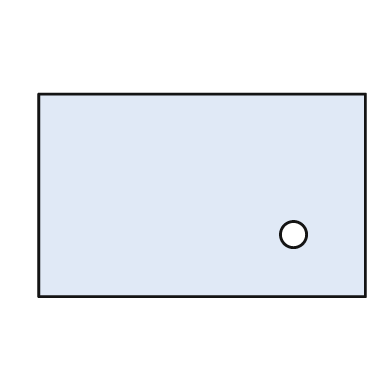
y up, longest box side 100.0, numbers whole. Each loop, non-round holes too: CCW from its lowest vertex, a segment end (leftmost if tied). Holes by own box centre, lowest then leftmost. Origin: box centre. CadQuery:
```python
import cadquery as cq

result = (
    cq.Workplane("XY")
    .moveTo(-50.0, -31.0)
    .lineTo(50.0, -31.0)
    .lineTo(50.0, 31.0)
    .lineTo(-50.0, 31.0)
    .close()
    .moveTo(28.0, -12.0)
    .circle(4.0)
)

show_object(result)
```